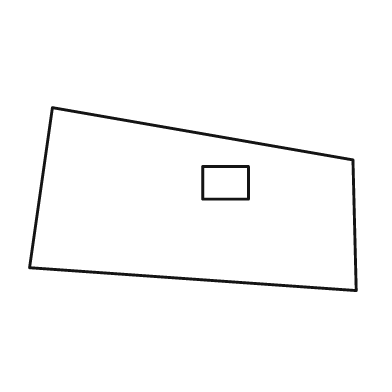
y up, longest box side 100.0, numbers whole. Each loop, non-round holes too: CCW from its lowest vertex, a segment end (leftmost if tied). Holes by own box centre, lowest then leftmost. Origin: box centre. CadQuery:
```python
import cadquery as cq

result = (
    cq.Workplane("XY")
    .moveTo(50.0, -28.0)
    .lineTo(49.0, 12.0)
    .lineTo(-43.0, 28.0)
    .lineTo(-50.0, -21.0)
    .close()
    .moveTo(3.0, 0.0)
    .lineTo(17.0, 0.0)
    .lineTo(17.0, 10.0)
    .lineTo(3.0, 10.0)
    .close()
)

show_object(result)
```